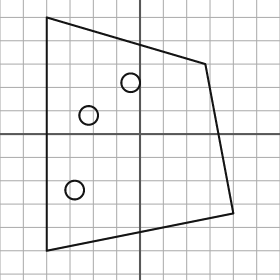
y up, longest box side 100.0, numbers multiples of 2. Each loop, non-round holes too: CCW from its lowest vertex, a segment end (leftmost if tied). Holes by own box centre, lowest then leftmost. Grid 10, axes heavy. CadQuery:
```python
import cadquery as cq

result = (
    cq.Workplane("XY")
    .moveTo(-40.0, -50.0)
    .lineTo(40.0, -34.0)
    .lineTo(28.0, 30.0)
    .lineTo(-40.0, 50.0)
    .close()
    .moveTo(-28.0, -24.0)
    .circle(4.0)
    .moveTo(-22.0, 8.0)
    .circle(4.0)
    .moveTo(-4.0, 22.0)
    .circle(4.0)
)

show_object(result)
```